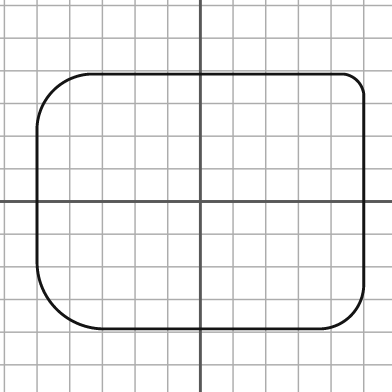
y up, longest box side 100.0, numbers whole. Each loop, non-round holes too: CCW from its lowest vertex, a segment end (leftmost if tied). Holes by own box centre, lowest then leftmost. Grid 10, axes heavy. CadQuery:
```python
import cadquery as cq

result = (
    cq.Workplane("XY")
    .moveTo(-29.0, -39.0)
    .lineTo(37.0, -39.0)
    .threePointArc((46.0, -35.0), (50.0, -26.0))
    .lineTo(50.0, 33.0)
    .threePointArc((48.0, 37.0), (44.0, 39.0))
    .lineTo(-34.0, 39.0)
    .threePointArc((-45.0, 34.0), (-50.0, 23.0))
    .lineTo(-50.0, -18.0)
    .threePointArc((-44.0, -33.0), (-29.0, -39.0))
    .close()
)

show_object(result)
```